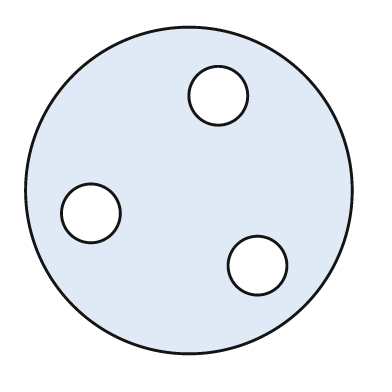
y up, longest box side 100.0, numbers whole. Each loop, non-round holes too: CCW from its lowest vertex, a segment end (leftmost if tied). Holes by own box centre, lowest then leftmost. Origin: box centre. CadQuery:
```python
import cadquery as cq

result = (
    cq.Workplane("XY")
    .moveTo(0.0, 0.0)
    .circle(50.0)
    .moveTo(21.0, -23.0)
    .circle(9.0)
    .moveTo(-30.0, -7.0)
    .circle(9.0)
    .moveTo(9.0, 29.0)
    .circle(9.0)
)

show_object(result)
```